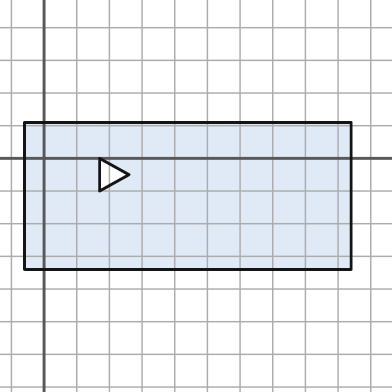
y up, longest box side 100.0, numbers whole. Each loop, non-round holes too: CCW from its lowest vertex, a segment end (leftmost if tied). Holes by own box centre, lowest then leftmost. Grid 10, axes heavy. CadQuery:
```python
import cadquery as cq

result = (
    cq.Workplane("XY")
    .moveTo(-6.0, -34.0)
    .lineTo(94.0, -34.0)
    .lineTo(94.0, 11.0)
    .lineTo(-6.0, 11.0)
    .close()
    .moveTo(17.0, -10.0)
    .lineTo(26.0, -5.0)
    .lineTo(17.0, 0.0)
    .close()
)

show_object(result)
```